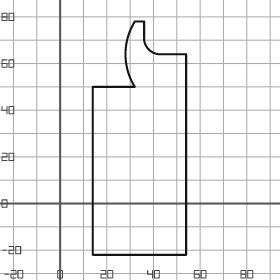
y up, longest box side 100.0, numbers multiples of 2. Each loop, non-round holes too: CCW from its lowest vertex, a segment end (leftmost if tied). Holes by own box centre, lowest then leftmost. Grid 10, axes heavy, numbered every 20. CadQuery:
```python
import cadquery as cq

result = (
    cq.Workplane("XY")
    .moveTo(14.0, -22.0)
    .lineTo(54.0, -22.0)
    .lineTo(54.0, 64.0)
    .lineTo(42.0, 64.0)
    .threePointArc((38.0, 66.0), (36.0, 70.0))
    .lineTo(36.0, 78.0)
    .lineTo(32.0, 78.0)
    .threePointArc((28.0, 64.0), (32.0, 50.0))
    .lineTo(14.0, 50.0)
    .close()
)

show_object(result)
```